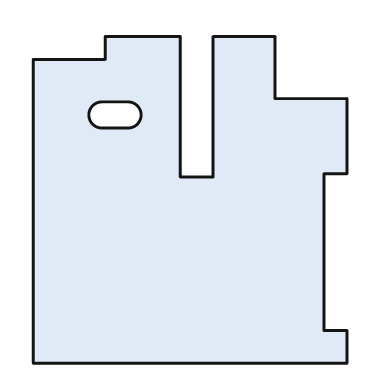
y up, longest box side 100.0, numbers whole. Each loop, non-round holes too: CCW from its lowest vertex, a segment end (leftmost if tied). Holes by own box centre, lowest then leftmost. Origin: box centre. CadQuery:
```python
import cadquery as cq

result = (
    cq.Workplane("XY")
    .moveTo(-48.0, -50.0)
    .lineTo(48.0, -50.0)
    .lineTo(48.0, -40.0)
    .lineTo(41.0, -40.0)
    .lineTo(41.0, 8.0)
    .lineTo(48.0, 8.0)
    .lineTo(48.0, 31.0)
    .lineTo(26.0, 31.0)
    .lineTo(26.0, 50.0)
    .lineTo(7.0, 50.0)
    .lineTo(7.0, 7.0)
    .lineTo(-3.0, 7.0)
    .lineTo(-3.0, 50.0)
    .lineTo(-26.0, 50.0)
    .lineTo(-26.0, 43.0)
    .lineTo(-48.0, 43.0)
    .close()
    .moveTo(-27.0, 22.0)
    .lineTo(-19.0, 22.0)
    .threePointArc((-15.0, 26.0), (-19.0, 30.0))
    .lineTo(-27.0, 30.0)
    .threePointArc((-31.0, 26.0), (-27.0, 22.0))
    .close()
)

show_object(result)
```